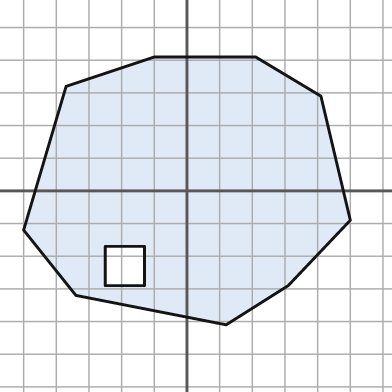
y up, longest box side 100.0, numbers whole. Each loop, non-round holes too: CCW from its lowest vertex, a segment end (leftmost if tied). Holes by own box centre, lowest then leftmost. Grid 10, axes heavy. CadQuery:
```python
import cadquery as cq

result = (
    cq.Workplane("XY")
    .moveTo(12.0, -41.0)
    .lineTo(31.0, -29.0)
    .lineTo(50.0, -9.0)
    .lineTo(41.0, 29.0)
    .lineTo(21.0, 41.0)
    .lineTo(-10.0, 41.0)
    .lineTo(-37.0, 32.0)
    .lineTo(-50.0, -12.0)
    .lineTo(-34.0, -32.0)
    .close()
    .moveTo(-25.0, -29.0)
    .lineTo(-13.0, -29.0)
    .lineTo(-13.0, -17.0)
    .lineTo(-25.0, -17.0)
    .close()
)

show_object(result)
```